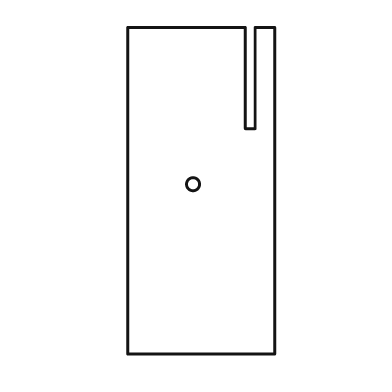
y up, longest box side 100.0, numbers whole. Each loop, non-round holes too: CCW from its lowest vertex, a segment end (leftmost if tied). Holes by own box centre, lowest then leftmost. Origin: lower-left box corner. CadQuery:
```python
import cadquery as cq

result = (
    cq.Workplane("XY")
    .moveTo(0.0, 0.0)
    .lineTo(45.0, 0.0)
    .lineTo(45.0, 100.0)
    .lineTo(39.0, 100.0)
    .lineTo(39.0, 69.0)
    .lineTo(36.0, 69.0)
    .lineTo(36.0, 100.0)
    .lineTo(0.0, 100.0)
    .close()
    .moveTo(20.0, 52.0)
    .circle(2.0)
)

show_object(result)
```